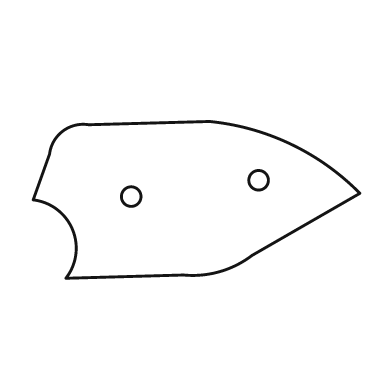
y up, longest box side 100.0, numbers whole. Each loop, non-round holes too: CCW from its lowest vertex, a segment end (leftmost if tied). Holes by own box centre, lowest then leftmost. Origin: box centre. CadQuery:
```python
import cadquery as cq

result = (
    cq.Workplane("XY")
    .moveTo(-40.0, -24.0)
    .lineTo(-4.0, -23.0)
    .threePointArc((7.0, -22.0), (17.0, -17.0))
    .lineTo(50.0, 2.0)
    .threePointArc((29.0, 17.0), (4.0, 24.0))
    .lineTo(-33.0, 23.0)
    .threePointArc((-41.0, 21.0), (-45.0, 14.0))
    .lineTo(-50.0, 0.0)
    .threePointArc((-38.0, -9.0), (-40.0, -24.0))
    .close()
    .moveTo(-20.0, 1.0)
    .circle(3.0)
    .moveTo(19.0, 6.0)
    .circle(3.0)
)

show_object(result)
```